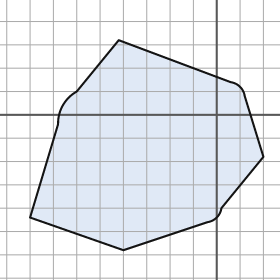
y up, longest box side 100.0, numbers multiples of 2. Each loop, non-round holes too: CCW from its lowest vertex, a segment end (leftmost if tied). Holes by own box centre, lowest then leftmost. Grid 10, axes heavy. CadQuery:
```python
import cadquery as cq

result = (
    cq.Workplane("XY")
    .moveTo(-40.0, -58.0)
    .lineTo(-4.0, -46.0)
    .threePointArc((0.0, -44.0), (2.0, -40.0))
    .lineTo(20.0, -18.0)
    .lineTo(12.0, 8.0)
    .threePointArc((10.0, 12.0), (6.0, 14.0))
    .lineTo(-42.0, 32.0)
    .lineTo(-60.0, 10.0)
    .threePointArc((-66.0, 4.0), (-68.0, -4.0))
    .lineTo(-80.0, -44.0)
    .close()
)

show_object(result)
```